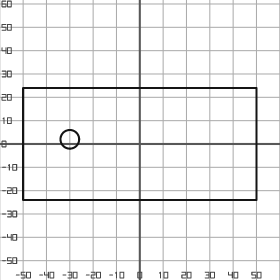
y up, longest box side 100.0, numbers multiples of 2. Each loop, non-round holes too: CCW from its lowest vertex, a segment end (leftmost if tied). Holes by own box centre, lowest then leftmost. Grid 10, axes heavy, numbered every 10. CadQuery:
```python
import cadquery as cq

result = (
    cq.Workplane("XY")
    .moveTo(-50.0, -24.0)
    .lineTo(50.0, -24.0)
    .lineTo(50.0, 24.0)
    .lineTo(-50.0, 24.0)
    .close()
    .moveTo(-30.0, 2.0)
    .circle(4.0)
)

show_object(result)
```